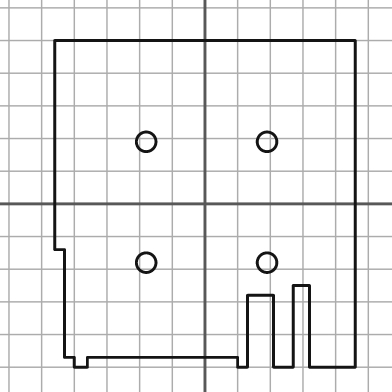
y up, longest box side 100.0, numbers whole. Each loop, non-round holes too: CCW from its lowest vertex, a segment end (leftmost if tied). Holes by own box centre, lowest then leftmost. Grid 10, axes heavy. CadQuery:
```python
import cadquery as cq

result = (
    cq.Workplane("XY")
    .moveTo(-40.0, -50.0)
    .lineTo(-36.0, -50.0)
    .lineTo(-36.0, -47.0)
    .lineTo(10.0, -47.0)
    .lineTo(10.0, -50.0)
    .lineTo(13.0, -50.0)
    .lineTo(13.0, -28.0)
    .lineTo(21.0, -28.0)
    .lineTo(21.0, -50.0)
    .lineTo(27.0, -50.0)
    .lineTo(27.0, -25.0)
    .lineTo(32.0, -25.0)
    .lineTo(32.0, -50.0)
    .lineTo(46.0, -50.0)
    .lineTo(46.0, 50.0)
    .lineTo(-46.0, 50.0)
    .lineTo(-46.0, -14.0)
    .lineTo(-43.0, -14.0)
    .lineTo(-43.0, -47.0)
    .lineTo(-40.0, -47.0)
    .close()
    .moveTo(-18.0, -18.0)
    .circle(3.0)
    .moveTo(19.0, -18.0)
    .circle(3.0)
    .moveTo(-18.0, 19.0)
    .circle(3.0)
    .moveTo(19.0, 19.0)
    .circle(3.0)
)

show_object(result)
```